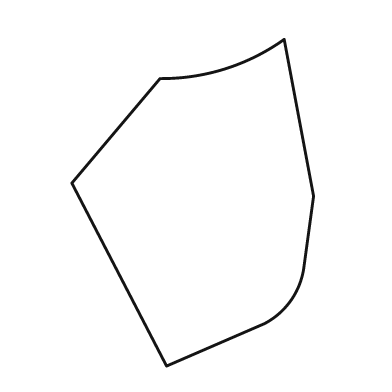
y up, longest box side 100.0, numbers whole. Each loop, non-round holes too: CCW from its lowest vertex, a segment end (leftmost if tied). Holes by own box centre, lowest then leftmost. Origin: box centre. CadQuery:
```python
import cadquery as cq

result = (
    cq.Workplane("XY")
    .moveTo(-8.0, -50.0)
    .lineTo(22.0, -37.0)
    .threePointArc((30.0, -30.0), (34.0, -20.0))
    .lineTo(37.0, 2.0)
    .lineTo(28.0, 50.0)
    .threePointArc((10.0, 41.0), (-10.0, 38.0))
    .lineTo(-37.0, 6.0)
    .close()
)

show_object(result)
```